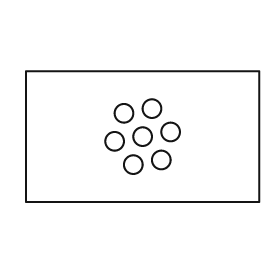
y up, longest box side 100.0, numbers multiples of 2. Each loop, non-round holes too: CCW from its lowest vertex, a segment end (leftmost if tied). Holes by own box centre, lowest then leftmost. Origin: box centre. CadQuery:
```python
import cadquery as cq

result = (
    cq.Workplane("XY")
    .moveTo(-50.0, -28.0)
    .lineTo(50.0, -28.0)
    .lineTo(50.0, 28.0)
    .lineTo(-50.0, 28.0)
    .close()
    .moveTo(-4.0, -12.0)
    .circle(4.0)
    .moveTo(8.0, -10.0)
    .circle(4.0)
    .moveTo(-12.0, -2.0)
    .circle(4.0)
    .moveTo(0.0, 0.0)
    .circle(4.0)
    .moveTo(12.0, 2.0)
    .circle(4.0)
    .moveTo(-8.0, 10.0)
    .circle(4.0)
    .moveTo(4.0, 12.0)
    .circle(4.0)
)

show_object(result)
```